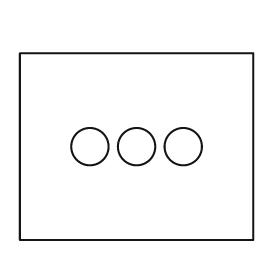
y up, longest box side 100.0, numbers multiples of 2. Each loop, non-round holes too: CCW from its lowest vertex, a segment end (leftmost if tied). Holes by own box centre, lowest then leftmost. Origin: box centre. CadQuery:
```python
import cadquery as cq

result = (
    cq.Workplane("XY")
    .moveTo(-50.0, -40.0)
    .lineTo(50.0, -40.0)
    .lineTo(50.0, 40.0)
    .lineTo(-50.0, 40.0)
    .close()
    .moveTo(-20.0, 0.0)
    .circle(8.0)
    .moveTo(0.0, 0.0)
    .circle(8.0)
    .moveTo(20.0, 0.0)
    .circle(8.0)
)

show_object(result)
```